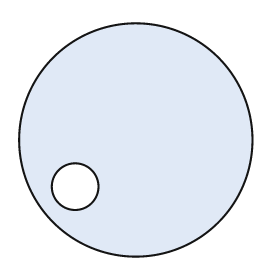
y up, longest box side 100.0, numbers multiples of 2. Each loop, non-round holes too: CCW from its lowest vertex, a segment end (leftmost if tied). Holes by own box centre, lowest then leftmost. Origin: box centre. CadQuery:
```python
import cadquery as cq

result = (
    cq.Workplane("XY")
    .moveTo(0.0, 0.0)
    .circle(50.0)
    .moveTo(-26.0, -20.0)
    .circle(10.0)
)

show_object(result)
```